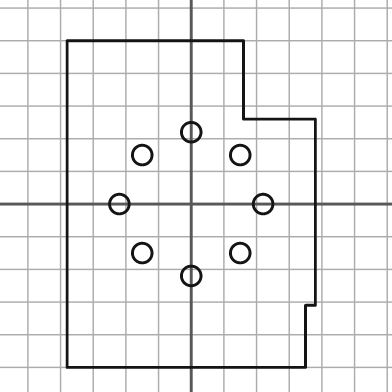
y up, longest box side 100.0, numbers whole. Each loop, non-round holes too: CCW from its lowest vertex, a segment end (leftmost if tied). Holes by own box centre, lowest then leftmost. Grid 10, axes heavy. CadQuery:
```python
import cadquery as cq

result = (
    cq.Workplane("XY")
    .moveTo(-38.0, -50.0)
    .lineTo(35.0, -50.0)
    .lineTo(35.0, -31.0)
    .lineTo(38.0, -31.0)
    .lineTo(38.0, 26.0)
    .lineTo(16.0, 26.0)
    .lineTo(16.0, 50.0)
    .lineTo(-38.0, 50.0)
    .close()
    .moveTo(0.0, -22.0)
    .circle(3.0)
    .moveTo(-15.0, -15.0)
    .circle(3.0)
    .moveTo(15.0, -15.0)
    .circle(3.0)
    .moveTo(-22.0, 0.0)
    .circle(3.0)
    .moveTo(22.0, 0.0)
    .circle(3.0)
    .moveTo(-15.0, 15.0)
    .circle(3.0)
    .moveTo(15.0, 15.0)
    .circle(3.0)
    .moveTo(0.0, 22.0)
    .circle(3.0)
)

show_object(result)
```